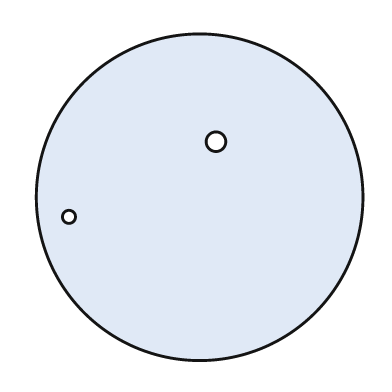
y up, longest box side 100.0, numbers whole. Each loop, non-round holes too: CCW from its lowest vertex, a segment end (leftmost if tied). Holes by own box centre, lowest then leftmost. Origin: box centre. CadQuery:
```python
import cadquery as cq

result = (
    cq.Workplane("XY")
    .moveTo(0.0, 0.0)
    .circle(50.0)
    .moveTo(-40.0, -6.0)
    .circle(2.0)
    .moveTo(5.0, 17.0)
    .circle(3.0)
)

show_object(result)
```